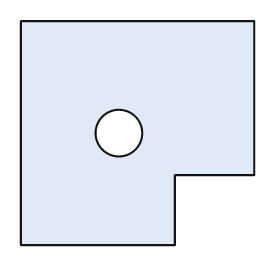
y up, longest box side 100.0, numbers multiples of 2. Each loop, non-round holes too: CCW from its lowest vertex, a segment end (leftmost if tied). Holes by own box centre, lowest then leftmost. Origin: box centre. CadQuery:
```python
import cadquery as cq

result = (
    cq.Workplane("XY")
    .moveTo(-50.0, -48.0)
    .lineTo(16.0, -48.0)
    .lineTo(16.0, -18.0)
    .lineTo(50.0, -18.0)
    .lineTo(50.0, 48.0)
    .lineTo(-50.0, 48.0)
    .close()
    .moveTo(-8.0, 0.0)
    .circle(10.0)
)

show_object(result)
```